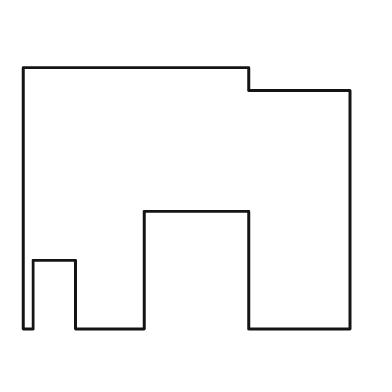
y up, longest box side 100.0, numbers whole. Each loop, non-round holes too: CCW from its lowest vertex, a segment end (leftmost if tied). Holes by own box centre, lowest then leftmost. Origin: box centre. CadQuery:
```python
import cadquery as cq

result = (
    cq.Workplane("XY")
    .moveTo(-50.0, -40.0)
    .lineTo(-47.0, -40.0)
    .lineTo(-47.0, -19.0)
    .lineTo(-34.0, -19.0)
    .lineTo(-34.0, -40.0)
    .lineTo(-13.0, -40.0)
    .lineTo(-13.0, -4.0)
    .lineTo(19.0, -4.0)
    .lineTo(19.0, -40.0)
    .lineTo(50.0, -40.0)
    .lineTo(50.0, 33.0)
    .lineTo(19.0, 33.0)
    .lineTo(19.0, 40.0)
    .lineTo(-50.0, 40.0)
    .close()
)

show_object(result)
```